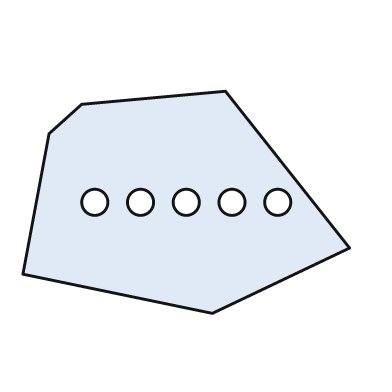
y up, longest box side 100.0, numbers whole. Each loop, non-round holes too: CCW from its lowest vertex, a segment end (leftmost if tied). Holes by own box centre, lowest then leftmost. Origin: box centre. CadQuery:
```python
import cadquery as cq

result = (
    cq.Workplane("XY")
    .moveTo(8.0, -34.0)
    .lineTo(50.0, -14.0)
    .lineTo(12.0, 34.0)
    .lineTo(-32.0, 30.0)
    .lineTo(-42.0, 21.0)
    .lineTo(-50.0, -22.0)
    .close()
    .moveTo(-28.0, 0.0)
    .circle(4.0)
    .moveTo(-14.0, 0.0)
    .circle(4.0)
    .moveTo(0.0, 0.0)
    .circle(4.0)
    .moveTo(14.0, 0.0)
    .circle(4.0)
    .moveTo(28.0, 0.0)
    .circle(4.0)
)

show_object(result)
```